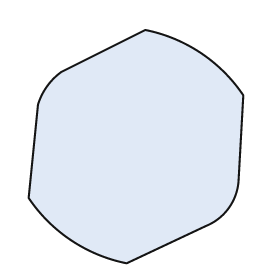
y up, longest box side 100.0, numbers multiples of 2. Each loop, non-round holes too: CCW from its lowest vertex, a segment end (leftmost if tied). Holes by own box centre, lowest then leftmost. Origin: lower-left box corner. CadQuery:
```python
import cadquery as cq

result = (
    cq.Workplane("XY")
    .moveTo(42.0, 0.0)
    .lineTo(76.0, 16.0)
    .threePointArc((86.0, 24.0), (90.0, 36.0))
    .lineTo(92.0, 72.0)
    .threePointArc((74.0, 90.0), (50.0, 100.0))
    .lineTo(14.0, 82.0)
    .threePointArc((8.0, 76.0), (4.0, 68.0))
    .lineTo(0.0, 28.0)
    .threePointArc((18.0, 10.0), (42.0, 0.0))
    .close()
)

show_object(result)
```